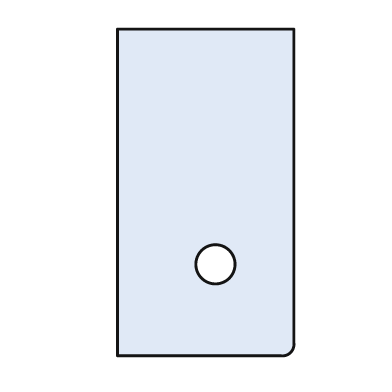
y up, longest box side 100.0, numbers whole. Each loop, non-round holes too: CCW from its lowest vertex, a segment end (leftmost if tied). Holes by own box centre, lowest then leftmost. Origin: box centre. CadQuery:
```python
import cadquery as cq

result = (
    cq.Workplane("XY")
    .moveTo(-27.0, -50.0)
    .lineTo(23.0, -50.0)
    .threePointArc((26.0, -49.0), (27.0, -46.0))
    .lineTo(27.0, 50.0)
    .lineTo(-27.0, 50.0)
    .close()
    .moveTo(3.0, -22.0)
    .circle(6.0)
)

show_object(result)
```